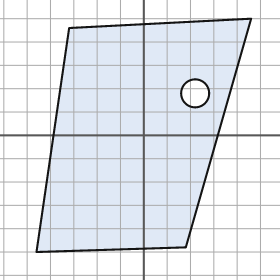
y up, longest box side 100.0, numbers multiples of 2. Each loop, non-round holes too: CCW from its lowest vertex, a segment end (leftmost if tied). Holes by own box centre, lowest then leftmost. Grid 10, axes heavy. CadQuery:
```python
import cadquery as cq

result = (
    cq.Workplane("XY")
    .moveTo(-46.0, -50.0)
    .lineTo(18.0, -48.0)
    .lineTo(46.0, 50.0)
    .lineTo(-32.0, 46.0)
    .close()
    .moveTo(22.0, 18.0)
    .circle(6.0)
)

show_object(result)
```